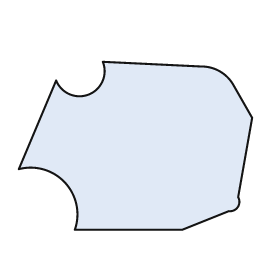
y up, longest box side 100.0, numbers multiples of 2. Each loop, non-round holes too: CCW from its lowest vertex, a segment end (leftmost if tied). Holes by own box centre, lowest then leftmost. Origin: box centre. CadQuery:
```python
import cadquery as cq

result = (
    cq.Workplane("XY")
    .moveTo(-26.0, -36.0)
    .lineTo(20.0, -36.0)
    .lineTo(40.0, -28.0)
    .threePointArc((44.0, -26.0), (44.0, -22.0))
    .lineTo(50.0, 12.0)
    .lineTo(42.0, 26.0)
    .threePointArc((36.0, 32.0), (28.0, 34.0))
    .lineTo(-14.0, 36.0)
    .threePointArc((-20.0, 22.0), (-34.0, 28.0))
    .lineTo(-50.0, -10.0)
    .threePointArc((-30.0, -16.0), (-26.0, -36.0))
    .close()
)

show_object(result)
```